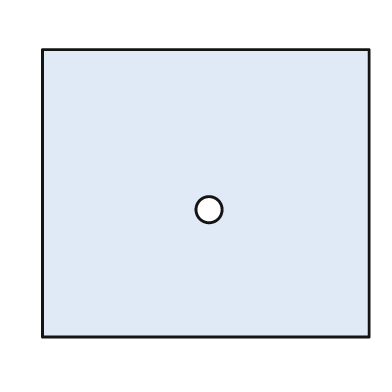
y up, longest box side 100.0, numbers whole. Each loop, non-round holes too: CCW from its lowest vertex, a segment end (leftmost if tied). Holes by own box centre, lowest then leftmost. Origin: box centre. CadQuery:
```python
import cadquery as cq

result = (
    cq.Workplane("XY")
    .moveTo(-50.0, -44.0)
    .lineTo(50.0, -44.0)
    .lineTo(50.0, 44.0)
    .lineTo(-50.0, 44.0)
    .close()
    .moveTo(1.0, -5.0)
    .circle(4.0)
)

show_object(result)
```